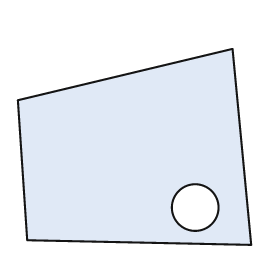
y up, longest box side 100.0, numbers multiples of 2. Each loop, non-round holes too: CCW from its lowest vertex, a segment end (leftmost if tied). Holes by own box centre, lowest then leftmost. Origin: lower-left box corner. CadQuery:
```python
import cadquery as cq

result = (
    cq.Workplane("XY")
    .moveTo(100.0, 0.0)
    .lineTo(92.0, 84.0)
    .lineTo(0.0, 62.0)
    .lineTo(4.0, 2.0)
    .close()
    .moveTo(76.0, 16.0)
    .circle(10.0)
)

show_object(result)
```